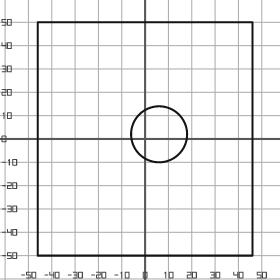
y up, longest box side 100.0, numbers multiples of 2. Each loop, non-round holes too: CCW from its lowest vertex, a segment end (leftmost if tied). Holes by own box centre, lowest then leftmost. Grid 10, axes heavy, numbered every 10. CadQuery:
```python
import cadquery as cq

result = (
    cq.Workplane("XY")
    .moveTo(-46.0, -50.0)
    .lineTo(46.0, -50.0)
    .lineTo(46.0, 50.0)
    .lineTo(-46.0, 50.0)
    .close()
    .moveTo(6.0, 2.0)
    .circle(12.0)
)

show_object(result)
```